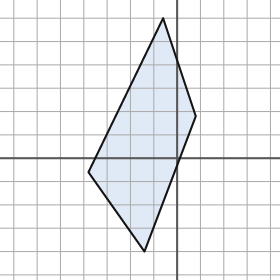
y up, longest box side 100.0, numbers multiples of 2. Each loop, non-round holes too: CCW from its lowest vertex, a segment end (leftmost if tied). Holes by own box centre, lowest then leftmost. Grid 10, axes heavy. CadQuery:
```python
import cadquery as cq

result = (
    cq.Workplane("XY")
    .moveTo(-14.0, -40.0)
    .lineTo(8.0, 18.0)
    .lineTo(-6.0, 60.0)
    .lineTo(-38.0, -6.0)
    .close()
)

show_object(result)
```